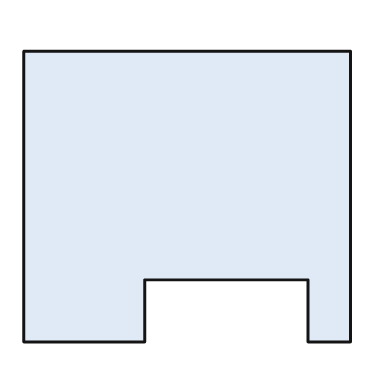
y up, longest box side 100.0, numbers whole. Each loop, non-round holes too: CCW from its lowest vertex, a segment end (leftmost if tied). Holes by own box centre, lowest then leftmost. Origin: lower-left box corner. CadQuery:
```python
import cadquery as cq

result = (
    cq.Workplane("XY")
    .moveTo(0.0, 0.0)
    .lineTo(37.0, 0.0)
    .lineTo(37.0, 19.0)
    .lineTo(87.0, 19.0)
    .lineTo(87.0, 0.0)
    .lineTo(100.0, 0.0)
    .lineTo(100.0, 89.0)
    .lineTo(0.0, 89.0)
    .close()
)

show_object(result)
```